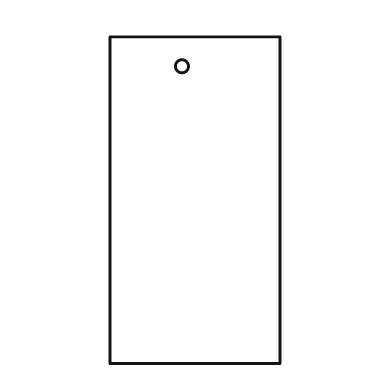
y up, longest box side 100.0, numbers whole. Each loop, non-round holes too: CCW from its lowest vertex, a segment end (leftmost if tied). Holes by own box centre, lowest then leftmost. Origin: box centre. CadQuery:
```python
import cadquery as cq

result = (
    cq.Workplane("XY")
    .moveTo(-26.0, -50.0)
    .lineTo(26.0, -50.0)
    .lineTo(26.0, 50.0)
    .lineTo(-26.0, 50.0)
    .close()
    .moveTo(-4.0, 41.0)
    .circle(2.0)
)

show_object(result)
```